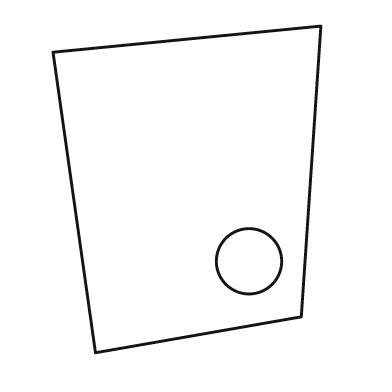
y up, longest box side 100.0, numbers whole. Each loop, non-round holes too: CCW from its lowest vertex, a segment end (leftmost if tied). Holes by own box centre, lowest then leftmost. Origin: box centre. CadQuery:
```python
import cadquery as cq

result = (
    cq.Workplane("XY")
    .moveTo(-28.0, -50.0)
    .lineTo(35.0, -39.0)
    .lineTo(41.0, 50.0)
    .lineTo(-41.0, 42.0)
    .close()
    .moveTo(19.0, -22.0)
    .circle(10.0)
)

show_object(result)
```